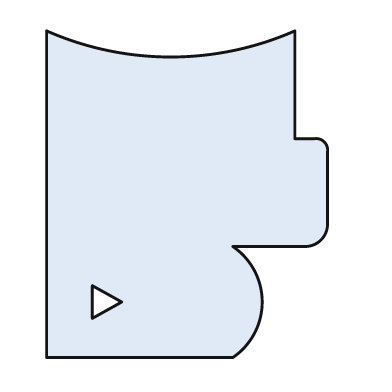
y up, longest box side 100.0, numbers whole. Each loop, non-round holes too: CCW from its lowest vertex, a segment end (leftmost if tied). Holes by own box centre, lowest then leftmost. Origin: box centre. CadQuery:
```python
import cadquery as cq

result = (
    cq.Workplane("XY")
    .moveTo(-43.0, -50.0)
    .lineTo(14.0, -50.0)
    .threePointArc((23.0, -33.0), (14.0, -16.0))
    .lineTo(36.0, -16.0)
    .threePointArc((41.0, -14.0), (43.0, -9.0))
    .lineTo(43.0, 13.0)
    .threePointArc((42.0, 16.0), (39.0, 17.0))
    .lineTo(33.0, 17.0)
    .lineTo(33.0, 50.0)
    .threePointArc((-5.0, 42.0), (-43.0, 50.0))
    .close()
    .moveTo(-29.0, -38.0)
    .lineTo(-20.0, -33.0)
    .lineTo(-29.0, -28.0)
    .close()
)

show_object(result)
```